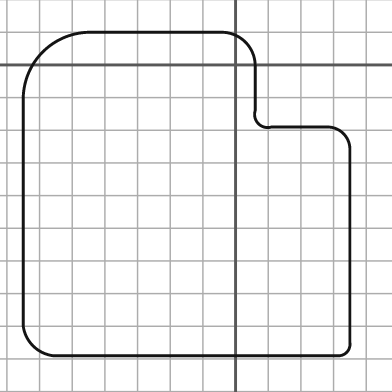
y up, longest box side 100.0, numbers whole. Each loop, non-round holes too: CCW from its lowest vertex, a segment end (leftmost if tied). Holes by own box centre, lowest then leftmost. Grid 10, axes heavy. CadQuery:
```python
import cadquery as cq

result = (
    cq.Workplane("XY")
    .moveTo(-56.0, -89.0)
    .lineTo(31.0, -89.0)
    .threePointArc((34.0, -88.0), (35.0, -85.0))
    .lineTo(35.0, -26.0)
    .threePointArc((33.0, -21.0), (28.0, -19.0))
    .lineTo(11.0, -19.0)
    .threePointArc((7.0, -18.0), (6.0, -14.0))
    .lineTo(6.0, 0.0)
    .threePointArc((3.0, 7.0), (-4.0, 10.0))
    .lineTo(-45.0, 10.0)
    .threePointArc((-59.0, 4.0), (-65.0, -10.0))
    .lineTo(-65.0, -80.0)
    .threePointArc((-62.0, -86.0), (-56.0, -89.0))
    .close()
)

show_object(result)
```